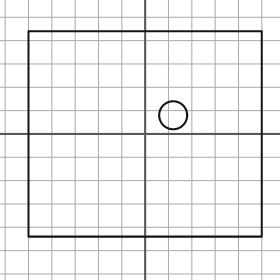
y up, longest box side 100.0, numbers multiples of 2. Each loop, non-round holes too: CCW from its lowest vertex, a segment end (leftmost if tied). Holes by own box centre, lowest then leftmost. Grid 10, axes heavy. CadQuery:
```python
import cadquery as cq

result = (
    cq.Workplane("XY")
    .moveTo(-50.0, -44.0)
    .lineTo(50.0, -44.0)
    .lineTo(50.0, 44.0)
    .lineTo(-50.0, 44.0)
    .close()
    .moveTo(12.0, 8.0)
    .circle(6.0)
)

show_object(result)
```